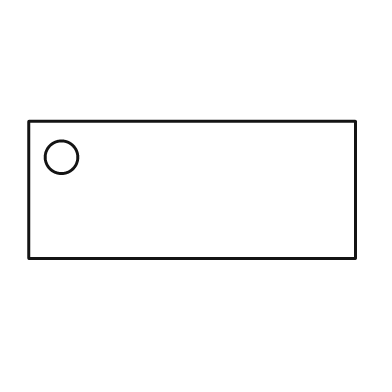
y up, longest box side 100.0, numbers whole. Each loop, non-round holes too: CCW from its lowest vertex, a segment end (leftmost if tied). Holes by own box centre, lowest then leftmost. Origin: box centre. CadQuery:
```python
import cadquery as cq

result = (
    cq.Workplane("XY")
    .moveTo(-50.0, -21.0)
    .lineTo(50.0, -21.0)
    .lineTo(50.0, 21.0)
    .lineTo(-50.0, 21.0)
    .close()
    .moveTo(-40.0, 10.0)
    .circle(5.0)
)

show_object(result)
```